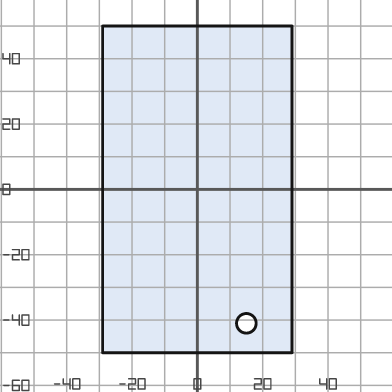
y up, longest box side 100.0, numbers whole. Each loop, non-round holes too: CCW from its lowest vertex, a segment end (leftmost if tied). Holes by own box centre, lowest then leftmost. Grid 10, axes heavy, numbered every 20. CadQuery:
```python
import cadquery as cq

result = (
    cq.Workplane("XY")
    .moveTo(-29.0, -50.0)
    .lineTo(29.0, -50.0)
    .lineTo(29.0, 50.0)
    .lineTo(-29.0, 50.0)
    .close()
    .moveTo(15.0, -41.0)
    .circle(3.0)
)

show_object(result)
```